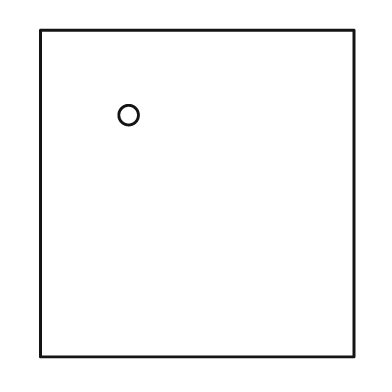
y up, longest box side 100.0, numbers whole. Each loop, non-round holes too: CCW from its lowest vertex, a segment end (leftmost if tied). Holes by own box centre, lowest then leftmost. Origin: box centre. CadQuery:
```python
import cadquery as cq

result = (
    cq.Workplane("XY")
    .moveTo(-48.0, -50.0)
    .lineTo(48.0, -50.0)
    .lineTo(48.0, 50.0)
    .lineTo(-48.0, 50.0)
    .close()
    .moveTo(-21.0, 24.0)
    .circle(3.0)
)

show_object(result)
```